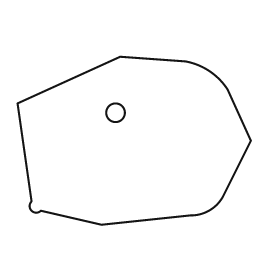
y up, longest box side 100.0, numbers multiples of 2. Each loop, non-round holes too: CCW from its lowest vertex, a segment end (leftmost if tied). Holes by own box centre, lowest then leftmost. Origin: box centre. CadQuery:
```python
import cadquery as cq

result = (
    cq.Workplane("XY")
    .moveTo(-14.0, -36.0)
    .lineTo(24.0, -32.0)
    .threePointArc((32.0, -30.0), (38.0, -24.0))
    .lineTo(50.0, 0.0)
    .lineTo(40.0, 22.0)
    .threePointArc((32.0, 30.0), (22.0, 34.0))
    .lineTo(-6.0, 36.0)
    .lineTo(-50.0, 16.0)
    .lineTo(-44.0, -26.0)
    .threePointArc((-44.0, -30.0), (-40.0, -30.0))
    .close()
    .moveTo(-8.0, 12.0)
    .circle(4.0)
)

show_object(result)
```